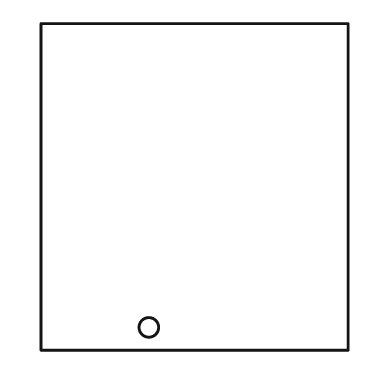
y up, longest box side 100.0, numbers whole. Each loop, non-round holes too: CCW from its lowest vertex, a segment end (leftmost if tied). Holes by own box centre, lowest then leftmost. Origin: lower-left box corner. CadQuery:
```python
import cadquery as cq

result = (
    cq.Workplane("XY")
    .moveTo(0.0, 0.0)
    .lineTo(94.0, 0.0)
    .lineTo(94.0, 100.0)
    .lineTo(0.0, 100.0)
    .close()
    .moveTo(33.0, 7.0)
    .circle(3.0)
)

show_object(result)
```